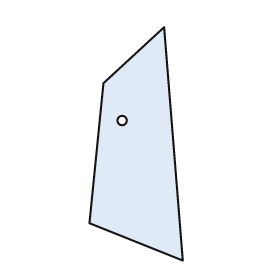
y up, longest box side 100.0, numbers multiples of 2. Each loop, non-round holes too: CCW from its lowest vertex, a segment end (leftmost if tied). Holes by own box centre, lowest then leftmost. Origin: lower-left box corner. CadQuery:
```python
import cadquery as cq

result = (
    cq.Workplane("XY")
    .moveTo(40.0, 0.0)
    .lineTo(32.0, 100.0)
    .lineTo(6.0, 76.0)
    .lineTo(0.0, 16.0)
    .close()
    .moveTo(14.0, 60.0)
    .circle(2.0)
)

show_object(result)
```